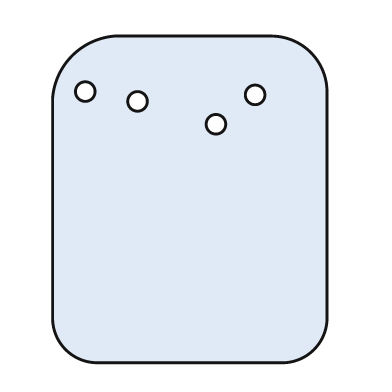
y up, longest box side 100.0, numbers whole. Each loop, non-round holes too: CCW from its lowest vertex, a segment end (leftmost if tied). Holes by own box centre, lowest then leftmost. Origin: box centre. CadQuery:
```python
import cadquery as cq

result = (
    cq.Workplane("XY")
    .moveTo(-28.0, -50.0)
    .lineTo(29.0, -50.0)
    .threePointArc((38.0, -46.0), (42.0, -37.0))
    .lineTo(42.0, 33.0)
    .threePointArc((37.0, 45.0), (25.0, 50.0))
    .lineTo(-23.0, 50.0)
    .threePointArc((-36.0, 44.0), (-42.0, 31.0))
    .lineTo(-42.0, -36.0)
    .threePointArc((-38.0, -46.0), (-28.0, -50.0))
    .close()
    .moveTo(8.0, 23.0)
    .circle(3.0)
    .moveTo(-16.0, 30.0)
    .circle(3.0)
    .moveTo(20.0, 32.0)
    .circle(3.0)
    .moveTo(-32.0, 33.0)
    .circle(3.0)
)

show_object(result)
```